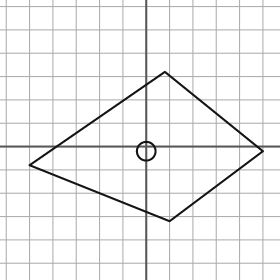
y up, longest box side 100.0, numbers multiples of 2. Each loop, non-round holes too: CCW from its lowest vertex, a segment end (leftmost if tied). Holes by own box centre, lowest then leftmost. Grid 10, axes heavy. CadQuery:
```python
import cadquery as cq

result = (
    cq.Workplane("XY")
    .moveTo(10.0, -32.0)
    .lineTo(50.0, -2.0)
    .lineTo(8.0, 32.0)
    .lineTo(-50.0, -8.0)
    .close()
    .moveTo(0.0, -2.0)
    .circle(4.0)
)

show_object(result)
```